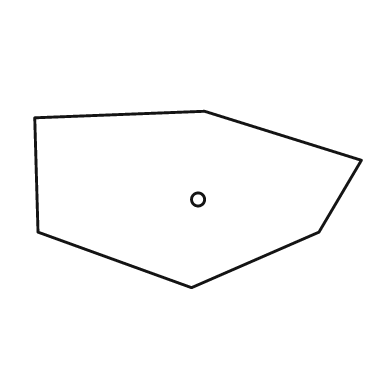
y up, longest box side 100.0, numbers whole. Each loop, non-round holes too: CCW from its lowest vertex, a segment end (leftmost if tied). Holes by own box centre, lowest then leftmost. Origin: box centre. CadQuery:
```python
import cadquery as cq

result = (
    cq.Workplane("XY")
    .moveTo(-2.0, -27.0)
    .lineTo(37.0, -10.0)
    .lineTo(50.0, 12.0)
    .lineTo(2.0, 27.0)
    .lineTo(-50.0, 25.0)
    .lineTo(-49.0, -10.0)
    .close()
    .moveTo(0.0, 0.0)
    .circle(2.0)
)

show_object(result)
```